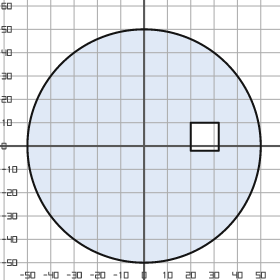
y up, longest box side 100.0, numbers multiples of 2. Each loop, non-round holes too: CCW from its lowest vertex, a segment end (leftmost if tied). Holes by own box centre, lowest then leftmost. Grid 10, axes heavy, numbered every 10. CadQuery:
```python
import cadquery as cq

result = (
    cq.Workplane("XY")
    .moveTo(0.0, 0.0)
    .circle(50.0)
    .moveTo(20.0, -2.0)
    .lineTo(32.0, -2.0)
    .lineTo(32.0, 10.0)
    .lineTo(20.0, 10.0)
    .close()
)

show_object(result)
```